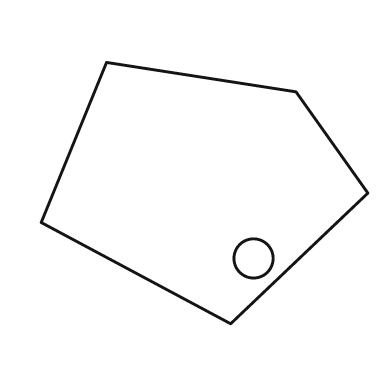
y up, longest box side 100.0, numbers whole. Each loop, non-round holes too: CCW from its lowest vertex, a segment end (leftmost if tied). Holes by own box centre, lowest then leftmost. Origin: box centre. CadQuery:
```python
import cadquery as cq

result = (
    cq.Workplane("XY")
    .moveTo(8.0, -40.0)
    .lineTo(50.0, 0.0)
    .lineTo(28.0, 31.0)
    .lineTo(-30.0, 40.0)
    .lineTo(-50.0, -9.0)
    .close()
    .moveTo(15.0, -20.0)
    .circle(6.0)
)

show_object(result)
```